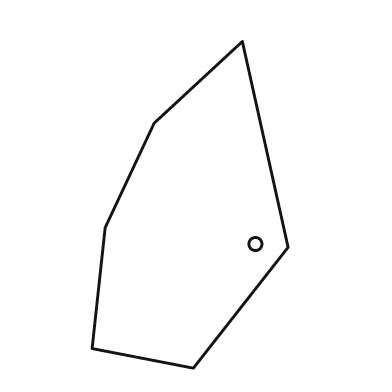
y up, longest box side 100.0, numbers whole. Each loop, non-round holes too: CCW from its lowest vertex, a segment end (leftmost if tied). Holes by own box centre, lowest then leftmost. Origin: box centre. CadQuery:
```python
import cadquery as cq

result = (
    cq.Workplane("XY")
    .moveTo(1.0, -50.0)
    .lineTo(30.0, -13.0)
    .lineTo(16.0, 50.0)
    .lineTo(-11.0, 25.0)
    .lineTo(-26.0, -7.0)
    .lineTo(-30.0, -44.0)
    .close()
    .moveTo(20.0, -12.0)
    .circle(2.0)
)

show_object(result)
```